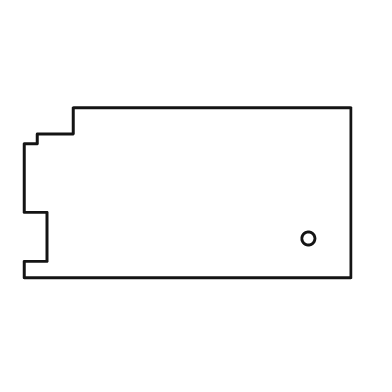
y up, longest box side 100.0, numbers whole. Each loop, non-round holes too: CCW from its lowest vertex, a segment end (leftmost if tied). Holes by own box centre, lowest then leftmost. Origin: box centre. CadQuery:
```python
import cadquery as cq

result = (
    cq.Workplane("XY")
    .moveTo(-50.0, -26.0)
    .lineTo(50.0, -26.0)
    .lineTo(50.0, 26.0)
    .lineTo(-35.0, 26.0)
    .lineTo(-35.0, 18.0)
    .lineTo(-46.0, 18.0)
    .lineTo(-46.0, 15.0)
    .lineTo(-50.0, 15.0)
    .lineTo(-50.0, -6.0)
    .lineTo(-43.0, -6.0)
    .lineTo(-43.0, -21.0)
    .lineTo(-50.0, -21.0)
    .close()
    .moveTo(37.0, -14.0)
    .circle(2.0)
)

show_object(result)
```